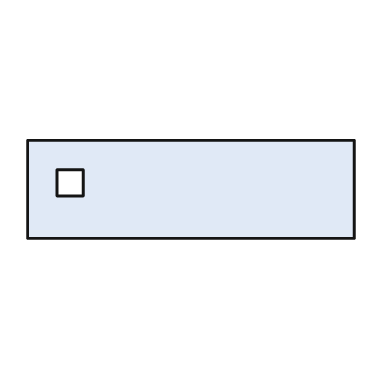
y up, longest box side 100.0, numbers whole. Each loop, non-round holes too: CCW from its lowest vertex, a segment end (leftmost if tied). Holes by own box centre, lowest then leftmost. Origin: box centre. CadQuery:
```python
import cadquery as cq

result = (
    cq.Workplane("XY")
    .moveTo(-50.0, -15.0)
    .lineTo(50.0, -15.0)
    .lineTo(50.0, 15.0)
    .lineTo(-50.0, 15.0)
    .close()
    .moveTo(-41.0, -2.0)
    .lineTo(-33.0, -2.0)
    .lineTo(-33.0, 6.0)
    .lineTo(-41.0, 6.0)
    .close()
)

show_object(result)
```